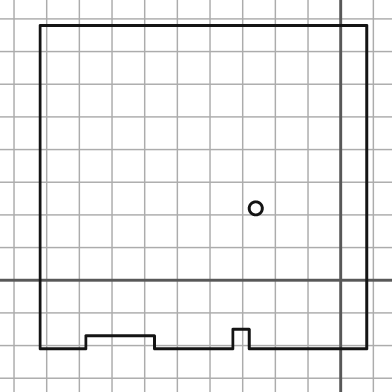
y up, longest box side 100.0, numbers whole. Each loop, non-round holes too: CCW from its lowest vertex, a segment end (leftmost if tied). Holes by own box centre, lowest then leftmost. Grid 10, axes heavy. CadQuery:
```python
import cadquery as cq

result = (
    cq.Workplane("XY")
    .moveTo(-92.0, -21.0)
    .lineTo(-78.0, -21.0)
    .lineTo(-78.0, -17.0)
    .lineTo(-57.0, -17.0)
    .lineTo(-57.0, -21.0)
    .lineTo(-33.0, -21.0)
    .lineTo(-33.0, -15.0)
    .lineTo(-28.0, -15.0)
    .lineTo(-28.0, -21.0)
    .lineTo(8.0, -21.0)
    .lineTo(8.0, 78.0)
    .lineTo(-92.0, 78.0)
    .close()
    .moveTo(-26.0, 22.0)
    .circle(2.0)
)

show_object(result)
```